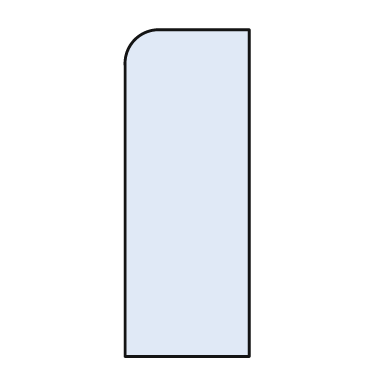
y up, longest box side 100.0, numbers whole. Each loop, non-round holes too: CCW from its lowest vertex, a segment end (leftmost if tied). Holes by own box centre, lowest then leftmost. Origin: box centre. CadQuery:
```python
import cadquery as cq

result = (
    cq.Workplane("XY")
    .moveTo(-19.0, -50.0)
    .lineTo(19.0, -50.0)
    .lineTo(19.0, 50.0)
    .lineTo(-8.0, 50.0)
    .threePointArc((-16.0, 47.0), (-19.0, 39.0))
    .close()
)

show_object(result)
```